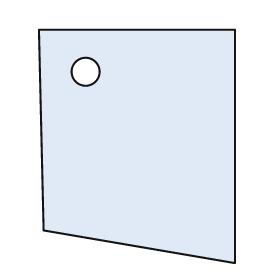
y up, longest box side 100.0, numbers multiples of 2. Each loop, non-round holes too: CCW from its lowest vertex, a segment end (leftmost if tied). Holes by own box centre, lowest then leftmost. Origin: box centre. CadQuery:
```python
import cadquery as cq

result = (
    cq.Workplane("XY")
    .moveTo(42.0, -50.0)
    .lineTo(42.0, 50.0)
    .lineTo(-42.0, 50.0)
    .lineTo(-40.0, -36.0)
    .close()
    .moveTo(-22.0, 32.0)
    .circle(6.0)
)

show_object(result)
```